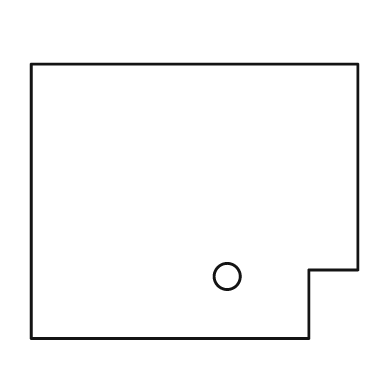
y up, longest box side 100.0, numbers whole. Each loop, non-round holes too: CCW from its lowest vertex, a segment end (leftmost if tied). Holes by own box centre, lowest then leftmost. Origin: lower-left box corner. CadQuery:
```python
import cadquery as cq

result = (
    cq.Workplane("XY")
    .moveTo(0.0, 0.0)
    .lineTo(85.0, 0.0)
    .lineTo(85.0, 21.0)
    .lineTo(100.0, 21.0)
    .lineTo(100.0, 84.0)
    .lineTo(0.0, 84.0)
    .close()
    .moveTo(60.0, 19.0)
    .circle(4.0)
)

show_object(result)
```